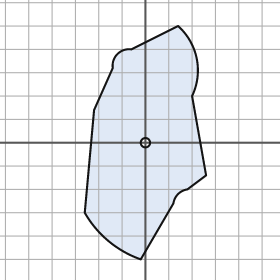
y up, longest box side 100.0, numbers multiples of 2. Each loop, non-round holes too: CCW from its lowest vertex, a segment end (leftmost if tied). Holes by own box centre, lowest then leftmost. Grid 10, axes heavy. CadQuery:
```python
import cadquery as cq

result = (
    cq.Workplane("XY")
    .moveTo(-2.0, -50.0)
    .lineTo(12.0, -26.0)
    .threePointArc((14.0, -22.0), (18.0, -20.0))
    .lineTo(26.0, -14.0)
    .lineTo(20.0, 20.0)
    .threePointArc((22.0, 36.0), (14.0, 50.0))
    .lineTo(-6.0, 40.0)
    .threePointArc((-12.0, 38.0), (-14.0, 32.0))
    .lineTo(-22.0, 14.0)
    .lineTo(-26.0, -30.0)
    .threePointArc((-16.0, -42.0), (-2.0, -50.0))
    .close()
    .moveTo(0.0, 0.0)
    .circle(2.0)
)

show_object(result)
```